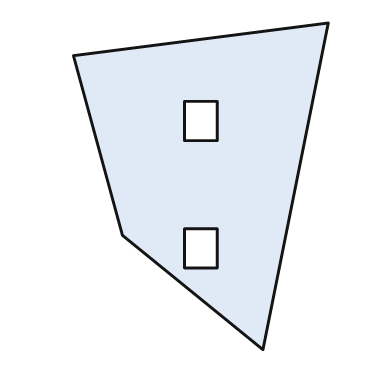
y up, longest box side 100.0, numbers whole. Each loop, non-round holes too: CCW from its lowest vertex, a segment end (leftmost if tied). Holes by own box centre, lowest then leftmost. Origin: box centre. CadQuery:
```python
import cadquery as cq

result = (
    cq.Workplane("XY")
    .moveTo(19.0, -50.0)
    .lineTo(39.0, 50.0)
    .lineTo(-39.0, 40.0)
    .lineTo(-24.0, -15.0)
    .close()
    .moveTo(-5.0, -25.0)
    .lineTo(5.0, -25.0)
    .lineTo(5.0, -13.0)
    .lineTo(-5.0, -13.0)
    .close()
    .moveTo(-5.0, 14.0)
    .lineTo(5.0, 14.0)
    .lineTo(5.0, 26.0)
    .lineTo(-5.0, 26.0)
    .close()
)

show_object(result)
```